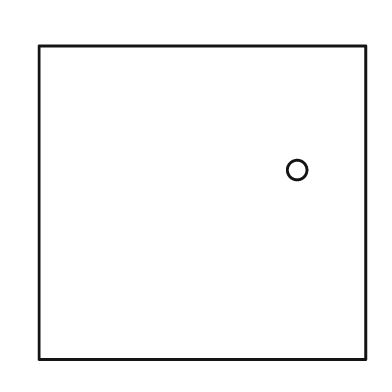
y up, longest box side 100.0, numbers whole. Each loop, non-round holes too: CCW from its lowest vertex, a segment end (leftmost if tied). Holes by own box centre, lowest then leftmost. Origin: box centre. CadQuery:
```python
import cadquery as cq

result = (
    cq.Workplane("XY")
    .moveTo(-50.0, -48.0)
    .lineTo(50.0, -48.0)
    .lineTo(50.0, 48.0)
    .lineTo(-50.0, 48.0)
    .close()
    .moveTo(29.0, 10.0)
    .circle(3.0)
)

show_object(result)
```